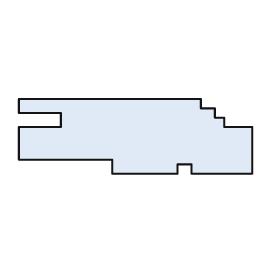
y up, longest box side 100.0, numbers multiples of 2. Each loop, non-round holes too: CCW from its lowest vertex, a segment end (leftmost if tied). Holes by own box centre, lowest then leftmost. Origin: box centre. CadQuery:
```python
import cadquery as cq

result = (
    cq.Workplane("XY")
    .moveTo(-10.0, -16.0)
    .lineTo(18.0, -16.0)
    .lineTo(18.0, -12.0)
    .lineTo(24.0, -12.0)
    .lineTo(24.0, -16.0)
    .lineTo(50.0, -16.0)
    .lineTo(50.0, 4.0)
    .lineTo(38.0, 4.0)
    .lineTo(38.0, 8.0)
    .lineTo(34.0, 8.0)
    .lineTo(34.0, 12.0)
    .lineTo(28.0, 12.0)
    .lineTo(28.0, 16.0)
    .lineTo(-50.0, 16.0)
    .lineTo(-50.0, 10.0)
    .lineTo(-32.0, 10.0)
    .lineTo(-32.0, 4.0)
    .lineTo(-50.0, 4.0)
    .lineTo(-50.0, -10.0)
    .lineTo(-10.0, -10.0)
    .close()
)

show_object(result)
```